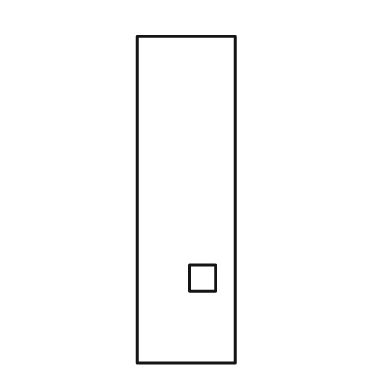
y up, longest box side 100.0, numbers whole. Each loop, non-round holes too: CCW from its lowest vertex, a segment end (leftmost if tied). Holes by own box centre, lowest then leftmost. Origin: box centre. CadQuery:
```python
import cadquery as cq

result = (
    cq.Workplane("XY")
    .moveTo(-15.0, -50.0)
    .lineTo(15.0, -50.0)
    .lineTo(15.0, 50.0)
    .lineTo(-15.0, 50.0)
    .close()
    .moveTo(1.0, -28.0)
    .lineTo(9.0, -28.0)
    .lineTo(9.0, -20.0)
    .lineTo(1.0, -20.0)
    .close()
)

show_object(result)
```